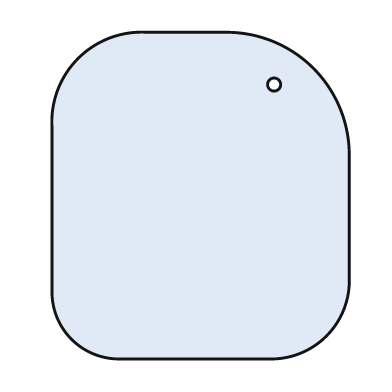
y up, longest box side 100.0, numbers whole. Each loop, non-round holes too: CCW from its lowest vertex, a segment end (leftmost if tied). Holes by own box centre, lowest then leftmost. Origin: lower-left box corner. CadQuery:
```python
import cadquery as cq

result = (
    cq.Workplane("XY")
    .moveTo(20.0, 0.0)
    .lineTo(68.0, 0.0)
    .threePointArc((84.0, 7.0), (91.0, 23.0))
    .lineTo(91.0, 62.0)
    .threePointArc((80.0, 89.0), (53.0, 100.0))
    .lineTo(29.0, 100.0)
    .threePointArc((8.0, 92.0), (0.0, 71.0))
    .lineTo(0.0, 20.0)
    .threePointArc((6.0, 6.0), (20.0, 0.0))
    .close()
    .moveTo(68.0, 84.0)
    .circle(2.0)
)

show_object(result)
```